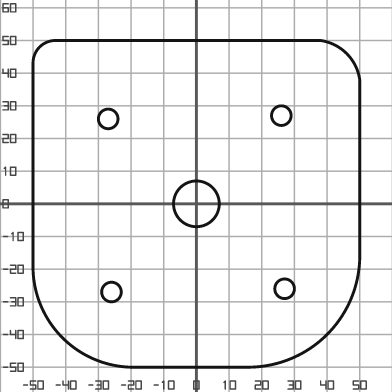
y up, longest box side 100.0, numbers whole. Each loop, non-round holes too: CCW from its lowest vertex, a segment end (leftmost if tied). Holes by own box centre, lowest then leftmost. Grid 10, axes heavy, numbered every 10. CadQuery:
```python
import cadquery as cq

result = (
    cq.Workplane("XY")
    .moveTo(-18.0, -50.0)
    .lineTo(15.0, -50.0)
    .threePointArc((40.0, -40.0), (50.0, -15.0))
    .lineTo(50.0, 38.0)
    .threePointArc((46.0, 46.0), (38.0, 50.0))
    .lineTo(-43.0, 50.0)
    .threePointArc((-48.0, 48.0), (-50.0, 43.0))
    .lineTo(-50.0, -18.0)
    .threePointArc((-41.0, -41.0), (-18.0, -50.0))
    .close()
    .moveTo(-26.0, -27.0)
    .circle(3.0)
    .moveTo(27.0, -26.0)
    .circle(3.0)
    .moveTo(0.0, 0.0)
    .circle(7.0)
    .moveTo(-27.0, 26.0)
    .circle(3.0)
    .moveTo(26.0, 27.0)
    .circle(3.0)
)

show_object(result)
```